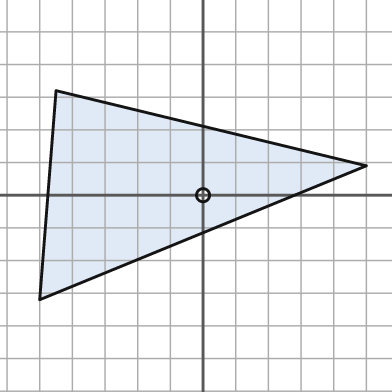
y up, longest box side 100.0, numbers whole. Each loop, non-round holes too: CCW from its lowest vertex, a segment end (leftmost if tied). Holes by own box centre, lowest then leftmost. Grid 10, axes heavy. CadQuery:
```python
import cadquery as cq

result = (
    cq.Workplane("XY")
    .moveTo(-50.0, -32.0)
    .lineTo(50.0, 9.0)
    .lineTo(-45.0, 32.0)
    .close()
    .moveTo(0.0, 0.0)
    .circle(2.0)
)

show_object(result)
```